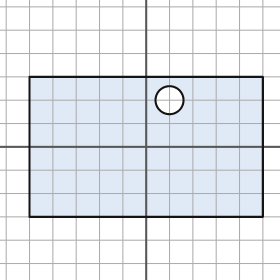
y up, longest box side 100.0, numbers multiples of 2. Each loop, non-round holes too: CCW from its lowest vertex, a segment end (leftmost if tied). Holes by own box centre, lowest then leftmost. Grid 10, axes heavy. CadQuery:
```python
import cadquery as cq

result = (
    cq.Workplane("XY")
    .moveTo(-50.0, -30.0)
    .lineTo(50.0, -30.0)
    .lineTo(50.0, 30.0)
    .lineTo(-50.0, 30.0)
    .close()
    .moveTo(10.0, 20.0)
    .circle(6.0)
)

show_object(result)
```